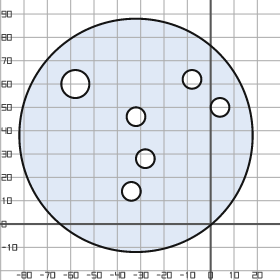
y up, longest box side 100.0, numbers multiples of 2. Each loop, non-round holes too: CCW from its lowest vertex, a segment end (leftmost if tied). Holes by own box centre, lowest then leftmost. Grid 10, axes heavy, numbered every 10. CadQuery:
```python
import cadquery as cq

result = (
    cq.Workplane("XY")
    .moveTo(-32.0, 38.0)
    .circle(50.0)
    .moveTo(-34.0, 14.0)
    .circle(4.0)
    .moveTo(-28.0, 28.0)
    .circle(4.0)
    .moveTo(-32.0, 46.0)
    .circle(4.0)
    .moveTo(4.0, 50.0)
    .circle(4.0)
    .moveTo(-58.0, 60.0)
    .circle(6.0)
    .moveTo(-8.0, 62.0)
    .circle(4.0)
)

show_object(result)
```